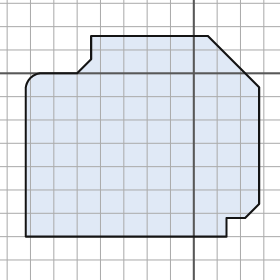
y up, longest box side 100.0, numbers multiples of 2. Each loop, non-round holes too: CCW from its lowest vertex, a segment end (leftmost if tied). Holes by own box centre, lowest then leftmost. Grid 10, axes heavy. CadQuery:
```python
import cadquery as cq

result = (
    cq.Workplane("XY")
    .moveTo(-72.0, -70.0)
    .lineTo(14.0, -70.0)
    .lineTo(14.0, -62.0)
    .lineTo(22.0, -62.0)
    .lineTo(28.0, -56.0)
    .lineTo(28.0, -6.0)
    .lineTo(6.0, 16.0)
    .lineTo(-44.0, 16.0)
    .lineTo(-44.0, 6.0)
    .lineTo(-50.0, 0.0)
    .lineTo(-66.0, 0.0)
    .threePointArc((-70.0, -2.0), (-72.0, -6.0))
    .close()
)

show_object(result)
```